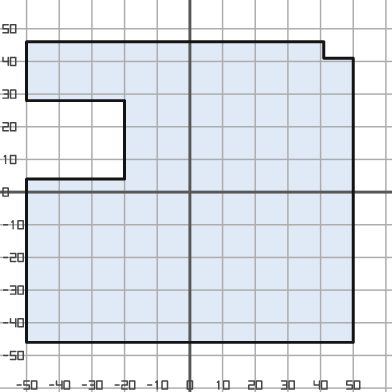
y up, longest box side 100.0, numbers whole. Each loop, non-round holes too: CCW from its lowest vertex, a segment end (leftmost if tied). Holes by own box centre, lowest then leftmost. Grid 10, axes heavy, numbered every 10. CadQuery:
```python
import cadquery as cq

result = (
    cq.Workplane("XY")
    .moveTo(-50.0, -46.0)
    .lineTo(50.0, -46.0)
    .lineTo(50.0, 41.0)
    .lineTo(41.0, 41.0)
    .lineTo(41.0, 46.0)
    .lineTo(-50.0, 46.0)
    .lineTo(-50.0, 28.0)
    .lineTo(-20.0, 28.0)
    .lineTo(-20.0, 4.0)
    .lineTo(-50.0, 4.0)
    .close()
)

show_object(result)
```